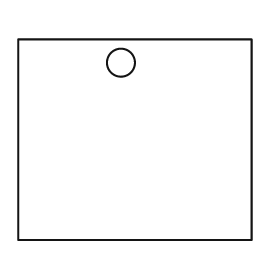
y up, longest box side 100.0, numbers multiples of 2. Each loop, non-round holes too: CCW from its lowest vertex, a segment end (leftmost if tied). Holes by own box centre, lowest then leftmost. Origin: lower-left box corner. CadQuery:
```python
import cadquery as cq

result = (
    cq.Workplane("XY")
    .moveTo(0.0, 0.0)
    .lineTo(100.0, 0.0)
    .lineTo(100.0, 86.0)
    .lineTo(0.0, 86.0)
    .close()
    .moveTo(44.0, 76.0)
    .circle(6.0)
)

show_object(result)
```